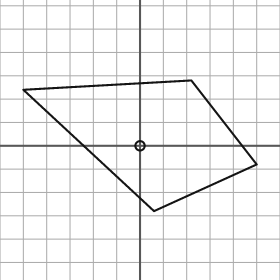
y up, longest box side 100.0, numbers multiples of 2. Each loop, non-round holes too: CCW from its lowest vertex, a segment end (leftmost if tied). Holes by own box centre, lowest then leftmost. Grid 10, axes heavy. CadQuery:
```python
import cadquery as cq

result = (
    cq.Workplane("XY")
    .moveTo(6.0, -28.0)
    .lineTo(50.0, -8.0)
    .lineTo(22.0, 28.0)
    .lineTo(-50.0, 24.0)
    .close()
    .moveTo(0.0, 0.0)
    .circle(2.0)
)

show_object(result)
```